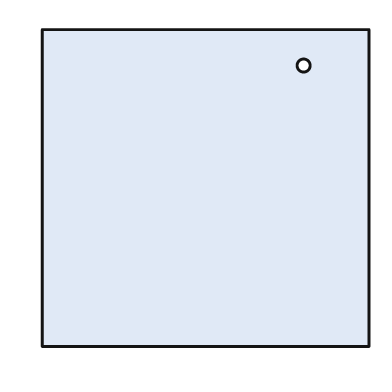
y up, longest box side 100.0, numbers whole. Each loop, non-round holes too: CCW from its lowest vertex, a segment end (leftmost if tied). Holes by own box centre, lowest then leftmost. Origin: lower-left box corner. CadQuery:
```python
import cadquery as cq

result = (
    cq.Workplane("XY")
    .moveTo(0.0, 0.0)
    .lineTo(100.0, 0.0)
    .lineTo(100.0, 97.0)
    .lineTo(0.0, 97.0)
    .close()
    .moveTo(80.0, 86.0)
    .circle(2.0)
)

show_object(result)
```